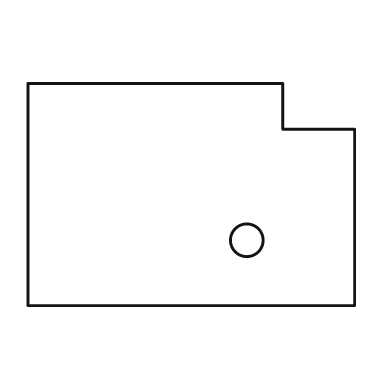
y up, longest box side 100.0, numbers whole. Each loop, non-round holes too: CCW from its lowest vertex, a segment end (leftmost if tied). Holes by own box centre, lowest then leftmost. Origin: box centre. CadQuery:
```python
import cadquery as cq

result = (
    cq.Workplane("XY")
    .moveTo(-50.0, -34.0)
    .lineTo(50.0, -34.0)
    .lineTo(50.0, 20.0)
    .lineTo(28.0, 20.0)
    .lineTo(28.0, 34.0)
    .lineTo(-50.0, 34.0)
    .close()
    .moveTo(17.0, -14.0)
    .circle(5.0)
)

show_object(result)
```